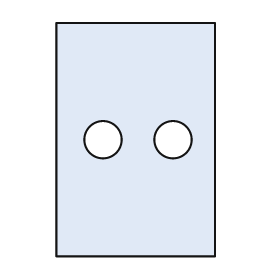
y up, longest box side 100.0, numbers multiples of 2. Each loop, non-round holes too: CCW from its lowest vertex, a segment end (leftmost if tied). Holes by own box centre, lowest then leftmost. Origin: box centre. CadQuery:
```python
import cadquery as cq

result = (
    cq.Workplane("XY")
    .moveTo(-34.0, -50.0)
    .lineTo(34.0, -50.0)
    .lineTo(34.0, 50.0)
    .lineTo(-34.0, 50.0)
    .close()
    .moveTo(-14.0, 0.0)
    .circle(8.0)
    .moveTo(16.0, 0.0)
    .circle(8.0)
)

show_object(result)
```